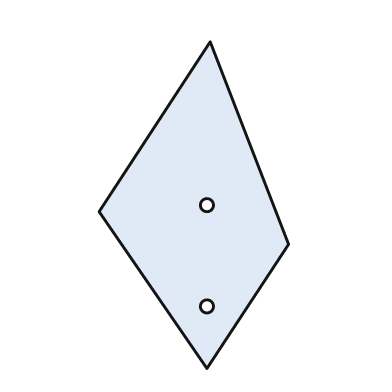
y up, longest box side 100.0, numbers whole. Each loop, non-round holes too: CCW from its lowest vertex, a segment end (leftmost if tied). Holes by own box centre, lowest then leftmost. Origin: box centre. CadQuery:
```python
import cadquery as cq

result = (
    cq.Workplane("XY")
    .moveTo(4.0, -50.0)
    .lineTo(29.0, -12.0)
    .lineTo(5.0, 50.0)
    .lineTo(-29.0, -2.0)
    .close()
    .moveTo(4.0, -31.0)
    .circle(2.0)
    .moveTo(4.0, 0.0)
    .circle(2.0)
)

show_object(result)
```